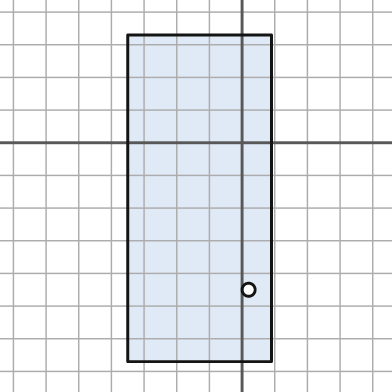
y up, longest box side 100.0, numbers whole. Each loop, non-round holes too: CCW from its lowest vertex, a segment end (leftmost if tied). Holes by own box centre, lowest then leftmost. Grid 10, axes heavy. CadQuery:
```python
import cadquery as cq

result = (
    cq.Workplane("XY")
    .moveTo(-35.0, -67.0)
    .lineTo(9.0, -67.0)
    .lineTo(9.0, 33.0)
    .lineTo(-35.0, 33.0)
    .close()
    .moveTo(2.0, -45.0)
    .circle(2.0)
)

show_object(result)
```